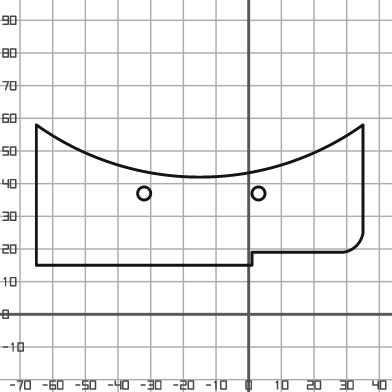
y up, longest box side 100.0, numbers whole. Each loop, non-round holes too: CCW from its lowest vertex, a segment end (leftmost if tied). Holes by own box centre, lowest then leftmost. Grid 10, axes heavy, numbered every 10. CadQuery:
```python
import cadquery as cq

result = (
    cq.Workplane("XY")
    .moveTo(-65.0, 15.0)
    .lineTo(1.0, 15.0)
    .lineTo(1.0, 19.0)
    .lineTo(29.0, 19.0)
    .threePointArc((33.0, 21.0), (35.0, 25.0))
    .lineTo(35.0, 58.0)
    .threePointArc((-15.0, 42.0), (-65.0, 58.0))
    .close()
    .moveTo(-32.0, 37.0)
    .circle(2.0)
    .moveTo(3.0, 37.0)
    .circle(2.0)
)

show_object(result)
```